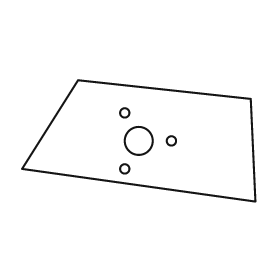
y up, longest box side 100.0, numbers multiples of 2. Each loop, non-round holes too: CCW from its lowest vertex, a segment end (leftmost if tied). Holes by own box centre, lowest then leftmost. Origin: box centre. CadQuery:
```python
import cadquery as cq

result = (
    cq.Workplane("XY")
    .moveTo(50.0, -26.0)
    .lineTo(48.0, 18.0)
    .lineTo(-26.0, 26.0)
    .lineTo(-50.0, -12.0)
    .close()
    .moveTo(-6.0, -12.0)
    .circle(2.0)
    .moveTo(0.0, 0.0)
    .circle(6.0)
    .moveTo(14.0, 0.0)
    .circle(2.0)
    .moveTo(-6.0, 12.0)
    .circle(2.0)
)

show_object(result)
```